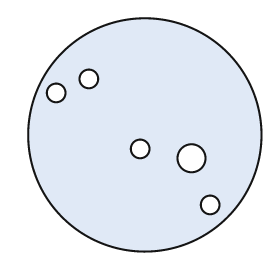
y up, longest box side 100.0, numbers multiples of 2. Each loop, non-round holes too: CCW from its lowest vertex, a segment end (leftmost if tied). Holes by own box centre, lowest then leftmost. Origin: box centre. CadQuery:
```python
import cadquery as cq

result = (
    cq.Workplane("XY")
    .moveTo(0.0, 0.0)
    .circle(50.0)
    .moveTo(28.0, -30.0)
    .circle(4.0)
    .moveTo(20.0, -10.0)
    .circle(6.0)
    .moveTo(-2.0, -6.0)
    .circle(4.0)
    .moveTo(-38.0, 18.0)
    .circle(4.0)
    .moveTo(-24.0, 24.0)
    .circle(4.0)
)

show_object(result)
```